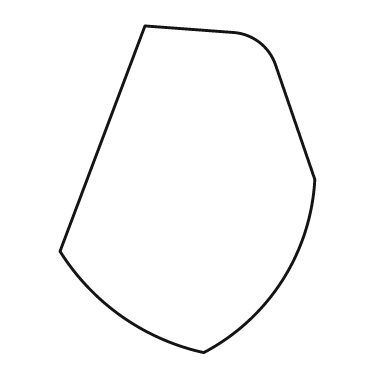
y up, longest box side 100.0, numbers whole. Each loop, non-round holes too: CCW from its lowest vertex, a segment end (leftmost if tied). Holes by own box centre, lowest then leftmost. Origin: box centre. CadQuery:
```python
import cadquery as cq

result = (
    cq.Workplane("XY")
    .moveTo(5.0, -50.0)
    .threePointArc((29.0, -28.0), (39.0, 3.0))
    .lineTo(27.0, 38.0)
    .threePointArc((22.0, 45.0), (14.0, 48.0))
    .lineTo(-13.0, 50.0)
    .lineTo(-39.0, -19.0)
    .threePointArc((-20.0, -39.0), (5.0, -50.0))
    .close()
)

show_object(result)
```